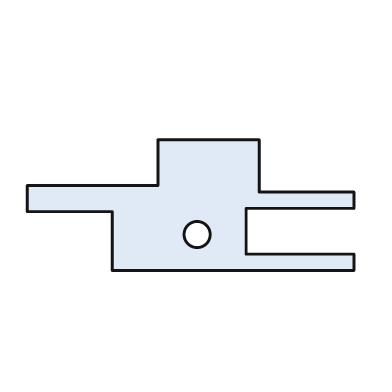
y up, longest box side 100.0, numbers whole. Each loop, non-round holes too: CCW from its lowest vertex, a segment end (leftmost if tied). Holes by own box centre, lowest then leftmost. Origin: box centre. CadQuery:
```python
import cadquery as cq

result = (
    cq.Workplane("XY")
    .moveTo(-24.0, -20.0)
    .lineTo(50.0, -20.0)
    .lineTo(50.0, -15.0)
    .lineTo(17.0, -15.0)
    .lineTo(17.0, -1.0)
    .lineTo(50.0, -1.0)
    .lineTo(50.0, 4.0)
    .lineTo(21.0, 4.0)
    .lineTo(21.0, 20.0)
    .lineTo(-10.0, 20.0)
    .lineTo(-10.0, 6.0)
    .lineTo(-50.0, 6.0)
    .lineTo(-50.0, -2.0)
    .lineTo(-24.0, -2.0)
    .close()
    .moveTo(2.0, -9.0)
    .circle(4.0)
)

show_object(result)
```